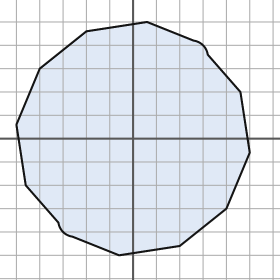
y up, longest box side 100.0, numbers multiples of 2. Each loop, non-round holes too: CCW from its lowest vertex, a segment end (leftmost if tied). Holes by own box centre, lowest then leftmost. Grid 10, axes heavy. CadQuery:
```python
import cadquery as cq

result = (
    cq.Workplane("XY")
    .moveTo(-6.0, -50.0)
    .lineTo(20.0, -46.0)
    .lineTo(40.0, -30.0)
    .lineTo(50.0, -6.0)
    .lineTo(46.0, 20.0)
    .lineTo(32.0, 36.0)
    .threePointArc((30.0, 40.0), (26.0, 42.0))
    .lineTo(6.0, 50.0)
    .lineTo(-20.0, 46.0)
    .lineTo(-40.0, 30.0)
    .lineTo(-50.0, 6.0)
    .lineTo(-46.0, -20.0)
    .lineTo(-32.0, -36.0)
    .threePointArc((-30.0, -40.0), (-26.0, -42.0))
    .close()
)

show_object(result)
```